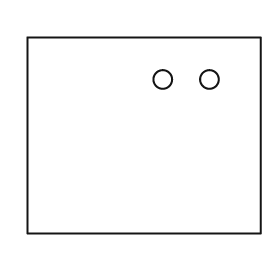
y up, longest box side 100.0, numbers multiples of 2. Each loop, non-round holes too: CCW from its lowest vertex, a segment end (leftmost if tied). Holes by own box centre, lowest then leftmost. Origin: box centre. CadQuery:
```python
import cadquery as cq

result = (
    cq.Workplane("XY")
    .moveTo(-50.0, -42.0)
    .lineTo(50.0, -42.0)
    .lineTo(50.0, 42.0)
    .lineTo(-50.0, 42.0)
    .close()
    .moveTo(8.0, 24.0)
    .circle(4.0)
    .moveTo(28.0, 24.0)
    .circle(4.0)
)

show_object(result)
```